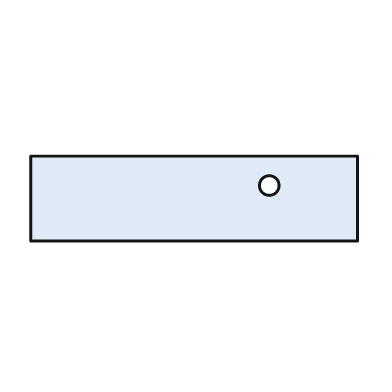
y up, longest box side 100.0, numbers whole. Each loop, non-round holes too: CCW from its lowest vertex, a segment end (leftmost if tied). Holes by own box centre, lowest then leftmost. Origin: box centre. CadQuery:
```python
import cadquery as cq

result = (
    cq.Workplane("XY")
    .moveTo(-50.0, -13.0)
    .lineTo(50.0, -13.0)
    .lineTo(50.0, 13.0)
    .lineTo(-50.0, 13.0)
    .close()
    .moveTo(23.0, 4.0)
    .circle(3.0)
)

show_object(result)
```